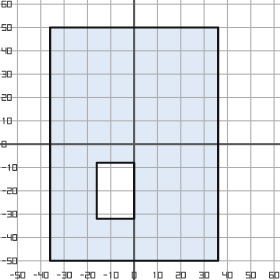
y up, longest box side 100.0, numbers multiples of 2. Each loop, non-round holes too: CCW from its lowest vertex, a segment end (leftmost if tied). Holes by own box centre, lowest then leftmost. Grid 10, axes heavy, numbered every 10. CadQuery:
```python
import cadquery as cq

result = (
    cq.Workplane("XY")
    .moveTo(-36.0, -50.0)
    .lineTo(36.0, -50.0)
    .lineTo(36.0, 50.0)
    .lineTo(-36.0, 50.0)
    .close()
    .moveTo(-16.0, -32.0)
    .lineTo(0.0, -32.0)
    .lineTo(0.0, -8.0)
    .lineTo(-16.0, -8.0)
    .close()
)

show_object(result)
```